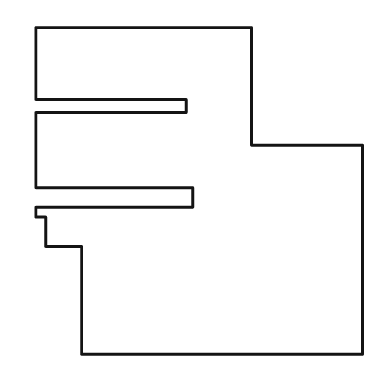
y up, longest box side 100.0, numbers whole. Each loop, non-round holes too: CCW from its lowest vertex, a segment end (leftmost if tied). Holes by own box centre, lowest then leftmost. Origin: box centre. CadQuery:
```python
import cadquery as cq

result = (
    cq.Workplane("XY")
    .moveTo(-36.0, -50.0)
    .lineTo(50.0, -50.0)
    .lineTo(50.0, 14.0)
    .lineTo(16.0, 14.0)
    .lineTo(16.0, 50.0)
    .lineTo(-50.0, 50.0)
    .lineTo(-50.0, 28.0)
    .lineTo(-4.0, 28.0)
    .lineTo(-4.0, 24.0)
    .lineTo(-50.0, 24.0)
    .lineTo(-50.0, 1.0)
    .lineTo(-2.0, 1.0)
    .lineTo(-2.0, -5.0)
    .lineTo(-50.0, -5.0)
    .lineTo(-50.0, -8.0)
    .lineTo(-47.0, -8.0)
    .lineTo(-47.0, -17.0)
    .lineTo(-36.0, -17.0)
    .close()
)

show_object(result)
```